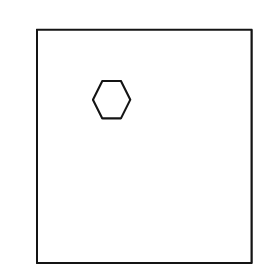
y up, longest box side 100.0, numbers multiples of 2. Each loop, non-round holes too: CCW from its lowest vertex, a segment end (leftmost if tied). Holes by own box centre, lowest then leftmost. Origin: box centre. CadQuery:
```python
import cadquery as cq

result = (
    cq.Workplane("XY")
    .moveTo(-46.0, -50.0)
    .lineTo(46.0, -50.0)
    .lineTo(46.0, 50.0)
    .lineTo(-46.0, 50.0)
    .close()
    .moveTo(-18.0, 12.0)
    .lineTo(-10.0, 12.0)
    .lineTo(-6.0, 20.0)
    .lineTo(-10.0, 28.0)
    .lineTo(-18.0, 28.0)
    .lineTo(-22.0, 20.0)
    .close()
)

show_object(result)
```